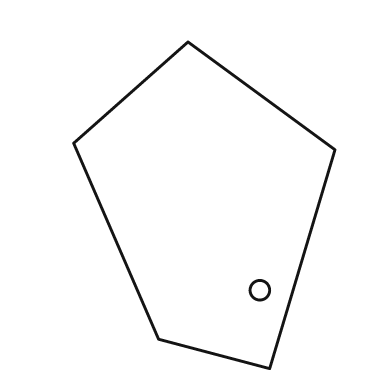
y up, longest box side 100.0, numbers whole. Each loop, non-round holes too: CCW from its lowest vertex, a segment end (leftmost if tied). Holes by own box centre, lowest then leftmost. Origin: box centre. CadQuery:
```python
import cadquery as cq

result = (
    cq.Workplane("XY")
    .moveTo(20.0, -50.0)
    .lineTo(40.0, 17.0)
    .lineTo(-5.0, 50.0)
    .lineTo(-40.0, 19.0)
    .lineTo(-14.0, -41.0)
    .close()
    .moveTo(17.0, -26.0)
    .circle(3.0)
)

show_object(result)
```